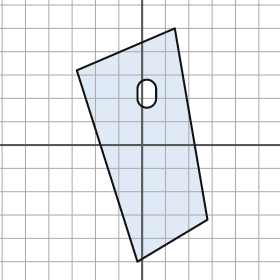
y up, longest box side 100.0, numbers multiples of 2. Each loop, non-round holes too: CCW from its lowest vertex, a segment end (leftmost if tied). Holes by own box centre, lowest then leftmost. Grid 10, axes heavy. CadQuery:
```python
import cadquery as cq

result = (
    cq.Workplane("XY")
    .moveTo(-2.0, -50.0)
    .lineTo(28.0, -32.0)
    .lineTo(14.0, 50.0)
    .lineTo(-28.0, 32.0)
    .close()
    .moveTo(-2.0, 20.0)
    .threePointArc((2.0, 16.0), (6.0, 20.0))
    .lineTo(6.0, 24.0)
    .threePointArc((2.0, 28.0), (-2.0, 24.0))
    .close()
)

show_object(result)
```